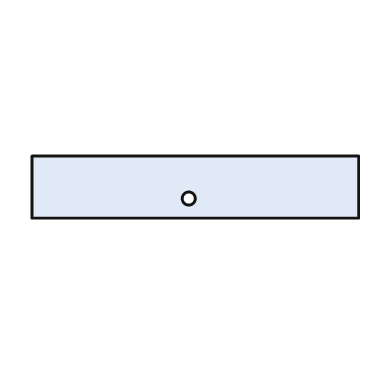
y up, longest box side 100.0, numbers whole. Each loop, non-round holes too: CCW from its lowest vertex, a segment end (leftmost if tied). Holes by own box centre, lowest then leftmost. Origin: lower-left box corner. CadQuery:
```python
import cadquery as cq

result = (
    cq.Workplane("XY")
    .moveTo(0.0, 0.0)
    .lineTo(100.0, 0.0)
    .lineTo(100.0, 19.0)
    .lineTo(0.0, 19.0)
    .close()
    .moveTo(48.0, 6.0)
    .circle(2.0)
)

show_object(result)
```